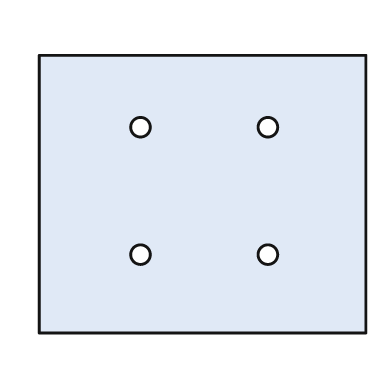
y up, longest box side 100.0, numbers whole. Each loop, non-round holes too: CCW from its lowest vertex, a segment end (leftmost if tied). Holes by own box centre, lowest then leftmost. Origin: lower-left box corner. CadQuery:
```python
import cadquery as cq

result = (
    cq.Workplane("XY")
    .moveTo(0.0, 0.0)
    .lineTo(100.0, 0.0)
    .lineTo(100.0, 85.0)
    .lineTo(0.0, 85.0)
    .close()
    .moveTo(31.0, 24.0)
    .circle(3.0)
    .moveTo(70.0, 24.0)
    .circle(3.0)
    .moveTo(31.0, 63.0)
    .circle(3.0)
    .moveTo(70.0, 63.0)
    .circle(3.0)
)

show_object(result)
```